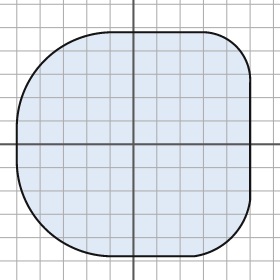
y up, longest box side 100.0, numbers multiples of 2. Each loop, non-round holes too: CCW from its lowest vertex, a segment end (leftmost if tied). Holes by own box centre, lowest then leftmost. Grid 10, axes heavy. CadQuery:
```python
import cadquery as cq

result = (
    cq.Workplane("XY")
    .moveTo(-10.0, -48.0)
    .lineTo(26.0, -48.0)
    .threePointArc((42.0, -40.0), (50.0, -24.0))
    .lineTo(50.0, 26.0)
    .threePointArc((44.0, 42.0), (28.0, 48.0))
    .lineTo(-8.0, 48.0)
    .threePointArc((-38.0, 36.0), (-50.0, 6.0))
    .lineTo(-50.0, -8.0)
    .threePointArc((-38.0, -36.0), (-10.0, -48.0))
    .close()
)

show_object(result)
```